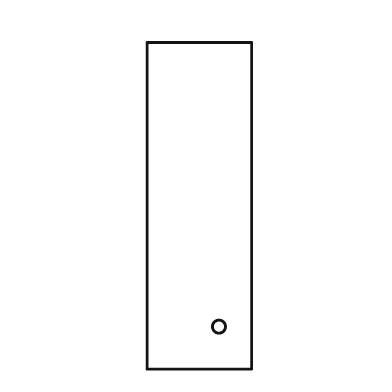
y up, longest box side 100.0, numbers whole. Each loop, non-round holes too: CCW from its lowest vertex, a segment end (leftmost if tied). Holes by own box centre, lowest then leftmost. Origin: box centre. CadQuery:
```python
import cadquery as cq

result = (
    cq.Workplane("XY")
    .moveTo(-16.0, -50.0)
    .lineTo(16.0, -50.0)
    .lineTo(16.0, 50.0)
    .lineTo(-16.0, 50.0)
    .close()
    .moveTo(6.0, -37.0)
    .circle(2.0)
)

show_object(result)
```